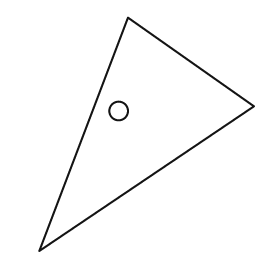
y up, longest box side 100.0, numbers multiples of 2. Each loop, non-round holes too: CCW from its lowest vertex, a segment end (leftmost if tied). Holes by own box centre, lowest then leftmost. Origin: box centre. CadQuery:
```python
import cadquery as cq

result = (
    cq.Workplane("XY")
    .moveTo(-46.0, -50.0)
    .lineTo(46.0, 12.0)
    .lineTo(-8.0, 50.0)
    .close()
    .moveTo(-12.0, 10.0)
    .circle(4.0)
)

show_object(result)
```